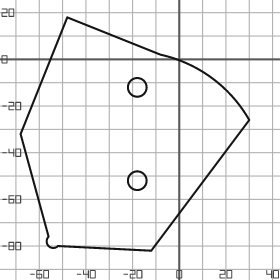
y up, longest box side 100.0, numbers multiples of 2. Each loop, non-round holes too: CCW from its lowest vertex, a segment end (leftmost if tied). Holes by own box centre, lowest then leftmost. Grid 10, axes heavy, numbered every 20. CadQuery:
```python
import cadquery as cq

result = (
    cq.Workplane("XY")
    .moveTo(-12.0, -82.0)
    .lineTo(30.0, -26.0)
    .threePointArc((14.0, -8.0), (-8.0, 2.0))
    .lineTo(-48.0, 18.0)
    .lineTo(-68.0, -32.0)
    .lineTo(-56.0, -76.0)
    .threePointArc((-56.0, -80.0), (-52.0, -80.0))
    .close()
    .moveTo(-18.0, -52.0)
    .circle(4.0)
    .moveTo(-18.0, -12.0)
    .circle(4.0)
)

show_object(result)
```